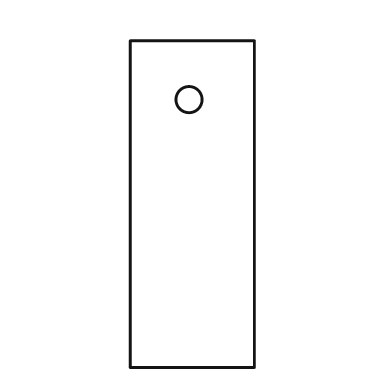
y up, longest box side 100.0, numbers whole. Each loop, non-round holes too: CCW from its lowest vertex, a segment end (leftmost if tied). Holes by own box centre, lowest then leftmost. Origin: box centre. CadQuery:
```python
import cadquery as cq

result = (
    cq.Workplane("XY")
    .moveTo(-19.0, -50.0)
    .lineTo(19.0, -50.0)
    .lineTo(19.0, 50.0)
    .lineTo(-19.0, 50.0)
    .close()
    .moveTo(-1.0, 32.0)
    .circle(4.0)
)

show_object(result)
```